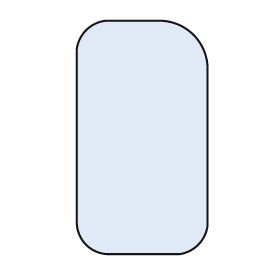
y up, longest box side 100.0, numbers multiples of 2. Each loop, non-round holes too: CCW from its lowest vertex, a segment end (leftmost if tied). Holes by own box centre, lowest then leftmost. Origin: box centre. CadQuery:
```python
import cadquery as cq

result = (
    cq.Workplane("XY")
    .moveTo(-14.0, -50.0)
    .lineTo(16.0, -50.0)
    .threePointArc((24.0, -46.0), (28.0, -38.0))
    .lineTo(28.0, 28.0)
    .threePointArc((22.0, 44.0), (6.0, 50.0))
    .lineTo(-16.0, 50.0)
    .threePointArc((-24.0, 46.0), (-28.0, 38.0))
    .lineTo(-28.0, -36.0)
    .threePointArc((-24.0, -46.0), (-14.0, -50.0))
    .close()
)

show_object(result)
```